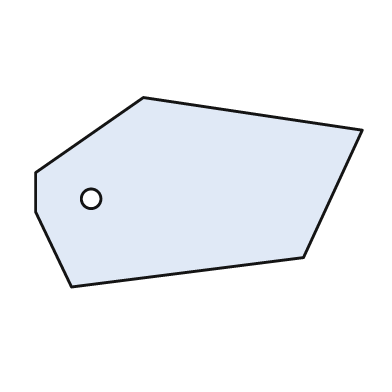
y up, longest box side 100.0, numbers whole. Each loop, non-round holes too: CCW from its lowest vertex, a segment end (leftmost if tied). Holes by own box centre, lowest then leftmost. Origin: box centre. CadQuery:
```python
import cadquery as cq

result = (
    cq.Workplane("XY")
    .moveTo(-39.0, -29.0)
    .lineTo(32.0, -20.0)
    .lineTo(50.0, 19.0)
    .lineTo(-17.0, 29.0)
    .lineTo(-50.0, 6.0)
    .lineTo(-50.0, -6.0)
    .close()
    .moveTo(-33.0, -2.0)
    .circle(3.0)
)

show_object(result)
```